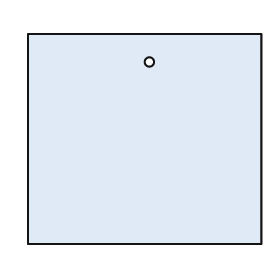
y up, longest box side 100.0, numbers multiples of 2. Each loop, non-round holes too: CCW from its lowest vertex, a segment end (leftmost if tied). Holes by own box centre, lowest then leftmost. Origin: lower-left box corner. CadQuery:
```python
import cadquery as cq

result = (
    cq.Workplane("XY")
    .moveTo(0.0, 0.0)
    .lineTo(100.0, 0.0)
    .lineTo(100.0, 90.0)
    .lineTo(0.0, 90.0)
    .close()
    .moveTo(52.0, 78.0)
    .circle(2.0)
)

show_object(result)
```